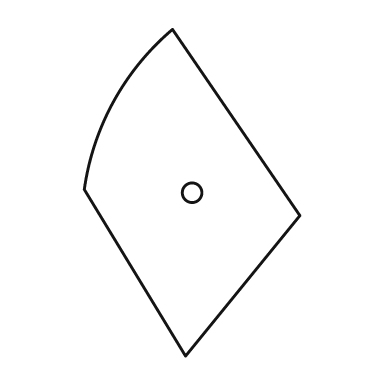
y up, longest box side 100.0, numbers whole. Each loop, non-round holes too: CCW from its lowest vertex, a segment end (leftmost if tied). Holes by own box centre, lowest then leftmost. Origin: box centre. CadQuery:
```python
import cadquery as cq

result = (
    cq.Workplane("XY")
    .moveTo(-2.0, -50.0)
    .lineTo(33.0, -7.0)
    .lineTo(-6.0, 50.0)
    .threePointArc((-24.0, 28.0), (-33.0, 1.0))
    .close()
    .moveTo(0.0, 0.0)
    .circle(3.0)
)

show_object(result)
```